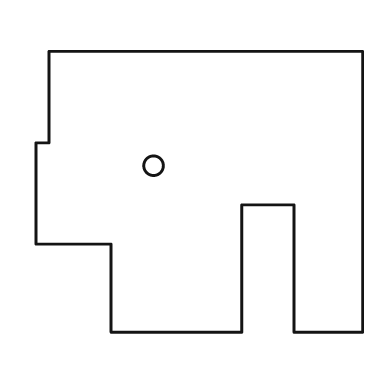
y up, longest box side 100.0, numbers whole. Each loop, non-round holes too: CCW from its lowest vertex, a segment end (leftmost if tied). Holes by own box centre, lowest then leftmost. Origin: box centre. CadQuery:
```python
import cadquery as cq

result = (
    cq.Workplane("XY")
    .moveTo(-27.0, -43.0)
    .lineTo(13.0, -43.0)
    .lineTo(13.0, -4.0)
    .lineTo(29.0, -4.0)
    .lineTo(29.0, -43.0)
    .lineTo(50.0, -43.0)
    .lineTo(50.0, 43.0)
    .lineTo(-46.0, 43.0)
    .lineTo(-46.0, 15.0)
    .lineTo(-50.0, 15.0)
    .lineTo(-50.0, -16.0)
    .lineTo(-27.0, -16.0)
    .close()
    .moveTo(-14.0, 8.0)
    .circle(3.0)
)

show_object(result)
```